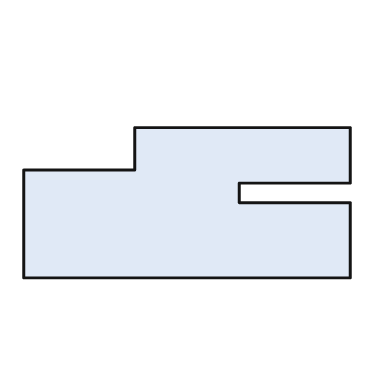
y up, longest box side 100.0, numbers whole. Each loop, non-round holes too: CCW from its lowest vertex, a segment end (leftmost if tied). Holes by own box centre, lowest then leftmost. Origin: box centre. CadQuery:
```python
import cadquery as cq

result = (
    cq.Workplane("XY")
    .moveTo(-50.0, -23.0)
    .lineTo(50.0, -23.0)
    .lineTo(50.0, 0.0)
    .lineTo(16.0, 0.0)
    .lineTo(16.0, 6.0)
    .lineTo(50.0, 6.0)
    .lineTo(50.0, 23.0)
    .lineTo(-16.0, 23.0)
    .lineTo(-16.0, 10.0)
    .lineTo(-50.0, 10.0)
    .close()
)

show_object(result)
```